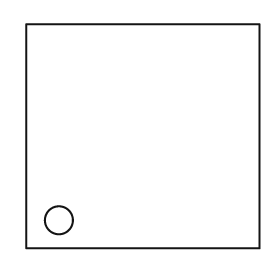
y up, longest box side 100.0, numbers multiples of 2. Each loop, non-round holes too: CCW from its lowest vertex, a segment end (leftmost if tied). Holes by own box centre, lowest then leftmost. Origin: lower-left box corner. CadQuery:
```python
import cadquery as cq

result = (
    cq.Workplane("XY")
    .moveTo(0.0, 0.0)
    .lineTo(100.0, 0.0)
    .lineTo(100.0, 96.0)
    .lineTo(0.0, 96.0)
    .close()
    .moveTo(14.0, 12.0)
    .circle(6.0)
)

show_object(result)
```